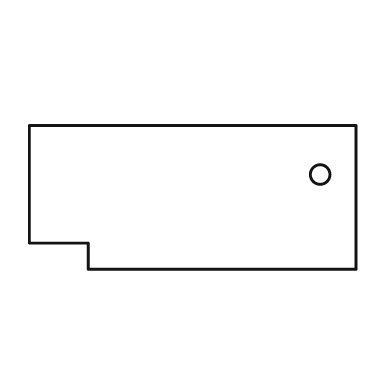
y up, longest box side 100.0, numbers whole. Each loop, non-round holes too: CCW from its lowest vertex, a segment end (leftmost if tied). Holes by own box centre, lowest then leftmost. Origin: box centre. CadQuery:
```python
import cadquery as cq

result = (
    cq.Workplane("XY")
    .moveTo(-32.0, -22.0)
    .lineTo(50.0, -22.0)
    .lineTo(50.0, 22.0)
    .lineTo(-50.0, 22.0)
    .lineTo(-50.0, -14.0)
    .lineTo(-32.0, -14.0)
    .close()
    .moveTo(39.0, 7.0)
    .circle(3.0)
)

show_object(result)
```